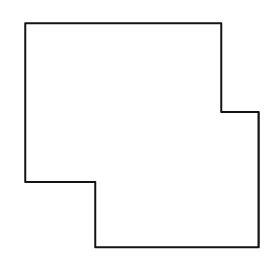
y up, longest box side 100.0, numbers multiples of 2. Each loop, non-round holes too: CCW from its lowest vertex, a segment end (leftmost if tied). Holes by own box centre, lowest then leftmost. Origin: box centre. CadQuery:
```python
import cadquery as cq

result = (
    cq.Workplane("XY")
    .moveTo(-20.0, -48.0)
    .lineTo(50.0, -48.0)
    .lineTo(50.0, 10.0)
    .lineTo(34.0, 10.0)
    .lineTo(34.0, 48.0)
    .lineTo(-50.0, 48.0)
    .lineTo(-50.0, -20.0)
    .lineTo(-20.0, -20.0)
    .close()
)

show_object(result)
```